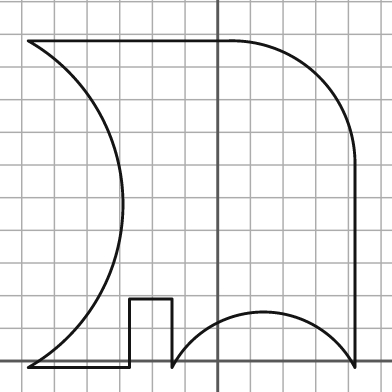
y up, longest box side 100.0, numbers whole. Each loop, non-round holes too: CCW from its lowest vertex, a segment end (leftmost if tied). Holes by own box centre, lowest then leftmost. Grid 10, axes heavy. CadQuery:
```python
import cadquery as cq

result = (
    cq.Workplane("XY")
    .moveTo(-58.0, -2.0)
    .lineTo(-27.0, -2.0)
    .lineTo(-27.0, 19.0)
    .lineTo(-14.0, 19.0)
    .lineTo(-14.0, -2.0)
    .threePointArc((14.0, 15.0), (42.0, -2.0))
    .lineTo(42.0, 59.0)
    .threePointArc((31.0, 87.0), (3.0, 98.0))
    .lineTo(-58.0, 98.0)
    .threePointArc((-29.0, 48.0), (-58.0, -2.0))
    .close()
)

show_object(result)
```